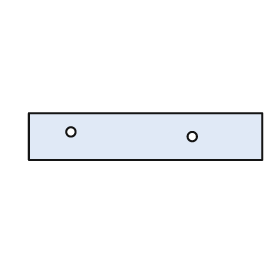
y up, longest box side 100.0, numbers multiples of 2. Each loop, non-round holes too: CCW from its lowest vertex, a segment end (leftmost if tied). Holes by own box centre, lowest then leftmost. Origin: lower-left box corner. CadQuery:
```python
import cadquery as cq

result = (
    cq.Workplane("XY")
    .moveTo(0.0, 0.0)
    .lineTo(100.0, 0.0)
    .lineTo(100.0, 20.0)
    .lineTo(0.0, 20.0)
    .close()
    .moveTo(70.0, 10.0)
    .circle(2.0)
    .moveTo(18.0, 12.0)
    .circle(2.0)
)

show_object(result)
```